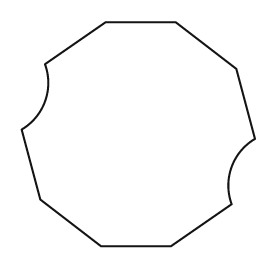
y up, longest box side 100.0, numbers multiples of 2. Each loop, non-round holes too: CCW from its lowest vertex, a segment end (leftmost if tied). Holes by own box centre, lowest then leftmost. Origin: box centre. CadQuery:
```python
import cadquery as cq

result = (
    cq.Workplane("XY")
    .moveTo(-16.0, -48.0)
    .lineTo(14.0, -48.0)
    .lineTo(40.0, -30.0)
    .threePointArc((40.0, -14.0), (50.0, -2.0))
    .lineTo(42.0, 28.0)
    .lineTo(16.0, 48.0)
    .lineTo(-14.0, 48.0)
    .lineTo(-40.0, 30.0)
    .threePointArc((-40.0, 14.0), (-50.0, 2.0))
    .lineTo(-42.0, -28.0)
    .close()
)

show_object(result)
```